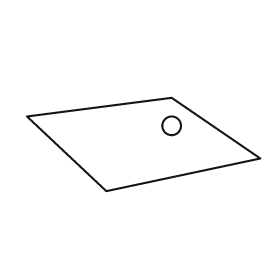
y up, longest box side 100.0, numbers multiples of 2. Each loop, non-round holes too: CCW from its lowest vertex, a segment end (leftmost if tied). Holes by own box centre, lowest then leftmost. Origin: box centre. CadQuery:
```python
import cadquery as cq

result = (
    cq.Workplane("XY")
    .moveTo(-16.0, -20.0)
    .lineTo(50.0, -6.0)
    .lineTo(12.0, 20.0)
    .lineTo(-50.0, 12.0)
    .close()
    .moveTo(12.0, 8.0)
    .circle(4.0)
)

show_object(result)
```